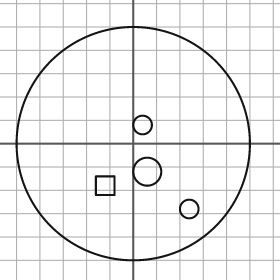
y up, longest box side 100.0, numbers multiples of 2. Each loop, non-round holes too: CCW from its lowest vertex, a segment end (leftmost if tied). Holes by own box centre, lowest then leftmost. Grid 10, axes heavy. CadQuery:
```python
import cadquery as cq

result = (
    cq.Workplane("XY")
    .moveTo(0.0, 0.0)
    .circle(50.0)
    .moveTo(24.0, -28.0)
    .circle(4.0)
    .moveTo(-16.0, -22.0)
    .lineTo(-8.0, -22.0)
    .lineTo(-8.0, -14.0)
    .lineTo(-16.0, -14.0)
    .close()
    .moveTo(6.0, -12.0)
    .circle(6.0)
    .moveTo(4.0, 8.0)
    .circle(4.0)
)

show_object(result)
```